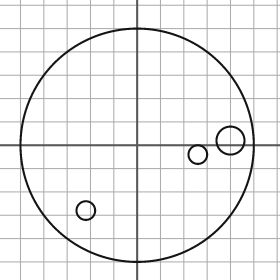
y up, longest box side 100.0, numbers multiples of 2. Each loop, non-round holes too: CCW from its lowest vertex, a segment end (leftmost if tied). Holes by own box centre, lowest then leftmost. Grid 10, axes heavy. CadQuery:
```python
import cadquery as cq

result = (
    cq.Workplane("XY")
    .moveTo(0.0, 0.0)
    .circle(50.0)
    .moveTo(-22.0, -28.0)
    .circle(4.0)
    .moveTo(26.0, -4.0)
    .circle(4.0)
    .moveTo(40.0, 2.0)
    .circle(6.0)
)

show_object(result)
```